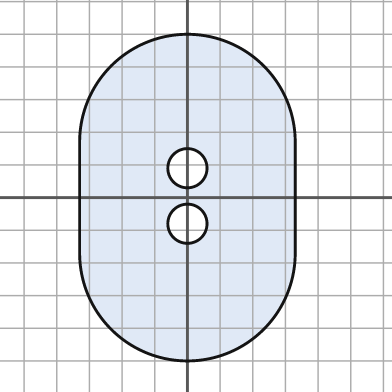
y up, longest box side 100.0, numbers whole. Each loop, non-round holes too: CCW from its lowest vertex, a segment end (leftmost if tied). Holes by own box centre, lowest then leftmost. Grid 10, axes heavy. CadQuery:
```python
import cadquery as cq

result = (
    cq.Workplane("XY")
    .moveTo(-33.0, -17.0)
    .threePointArc((0.0, -50.0), (33.0, -17.0))
    .lineTo(33.0, 17.0)
    .threePointArc((0.0, 50.0), (-33.0, 17.0))
    .close()
    .moveTo(0.0, -8.0)
    .circle(6.0)
    .moveTo(0.0, 9.0)
    .circle(6.0)
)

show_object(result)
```